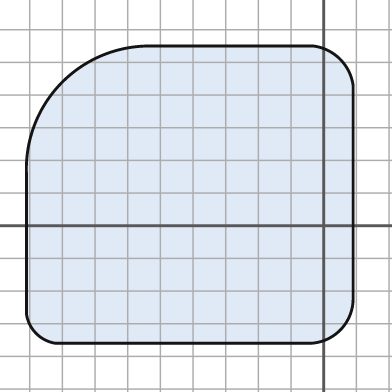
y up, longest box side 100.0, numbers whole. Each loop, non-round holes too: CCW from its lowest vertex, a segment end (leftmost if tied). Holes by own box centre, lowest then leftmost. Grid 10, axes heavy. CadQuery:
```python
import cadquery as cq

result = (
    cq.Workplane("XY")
    .moveTo(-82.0, -36.0)
    .lineTo(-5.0, -36.0)
    .threePointArc((5.0, -32.0), (9.0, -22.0))
    .lineTo(9.0, 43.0)
    .threePointArc((5.0, 51.0), (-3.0, 55.0))
    .lineTo(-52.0, 55.0)
    .threePointArc((-80.0, 44.0), (-91.0, 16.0))
    .lineTo(-91.0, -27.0)
    .threePointArc((-88.0, -33.0), (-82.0, -36.0))
    .close()
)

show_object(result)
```